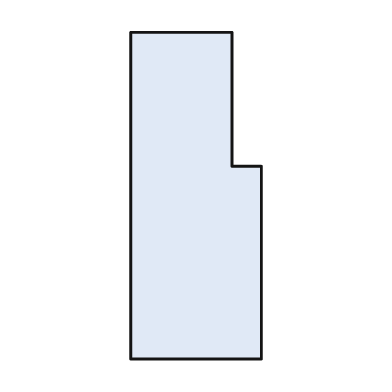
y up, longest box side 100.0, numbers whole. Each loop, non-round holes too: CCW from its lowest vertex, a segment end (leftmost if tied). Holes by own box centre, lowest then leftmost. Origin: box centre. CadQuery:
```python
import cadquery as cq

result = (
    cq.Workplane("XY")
    .moveTo(-20.0, -50.0)
    .lineTo(20.0, -50.0)
    .lineTo(20.0, 9.0)
    .lineTo(11.0, 9.0)
    .lineTo(11.0, 50.0)
    .lineTo(-20.0, 50.0)
    .close()
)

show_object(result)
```